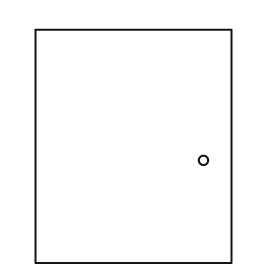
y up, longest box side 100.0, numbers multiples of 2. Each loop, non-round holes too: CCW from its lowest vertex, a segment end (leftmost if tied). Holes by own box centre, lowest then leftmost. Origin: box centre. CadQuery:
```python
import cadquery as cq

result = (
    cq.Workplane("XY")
    .moveTo(-42.0, -50.0)
    .lineTo(42.0, -50.0)
    .lineTo(42.0, 50.0)
    .lineTo(-42.0, 50.0)
    .close()
    .moveTo(30.0, -6.0)
    .circle(2.0)
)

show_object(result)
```